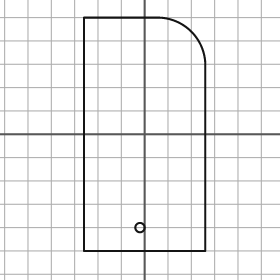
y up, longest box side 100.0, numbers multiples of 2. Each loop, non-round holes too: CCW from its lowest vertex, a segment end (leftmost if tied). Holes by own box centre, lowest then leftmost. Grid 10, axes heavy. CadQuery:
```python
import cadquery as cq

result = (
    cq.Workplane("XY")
    .moveTo(-26.0, -50.0)
    .lineTo(26.0, -50.0)
    .lineTo(26.0, 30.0)
    .threePointArc((20.0, 44.0), (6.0, 50.0))
    .lineTo(-26.0, 50.0)
    .close()
    .moveTo(-2.0, -40.0)
    .circle(2.0)
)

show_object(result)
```